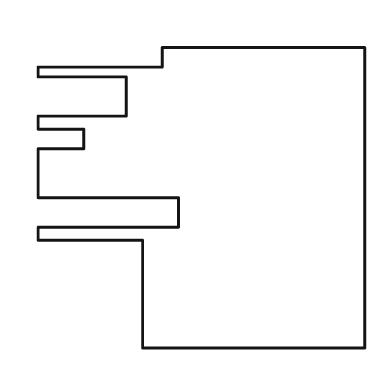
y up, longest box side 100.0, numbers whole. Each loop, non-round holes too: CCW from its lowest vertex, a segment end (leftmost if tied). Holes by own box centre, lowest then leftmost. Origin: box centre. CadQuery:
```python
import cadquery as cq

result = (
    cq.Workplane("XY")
    .moveTo(-18.0, -46.0)
    .lineTo(50.0, -46.0)
    .lineTo(50.0, 46.0)
    .lineTo(-12.0, 46.0)
    .lineTo(-12.0, 40.0)
    .lineTo(-50.0, 40.0)
    .lineTo(-50.0, 37.0)
    .lineTo(-23.0, 37.0)
    .lineTo(-23.0, 25.0)
    .lineTo(-50.0, 25.0)
    .lineTo(-50.0, 21.0)
    .lineTo(-36.0, 21.0)
    .lineTo(-36.0, 15.0)
    .lineTo(-50.0, 15.0)
    .lineTo(-50.0, 0.0)
    .lineTo(-7.0, 0.0)
    .lineTo(-7.0, -9.0)
    .lineTo(-50.0, -9.0)
    .lineTo(-50.0, -13.0)
    .lineTo(-18.0, -13.0)
    .close()
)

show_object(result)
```